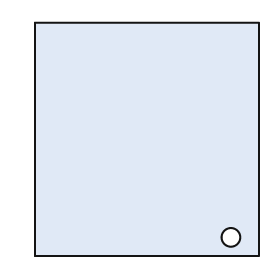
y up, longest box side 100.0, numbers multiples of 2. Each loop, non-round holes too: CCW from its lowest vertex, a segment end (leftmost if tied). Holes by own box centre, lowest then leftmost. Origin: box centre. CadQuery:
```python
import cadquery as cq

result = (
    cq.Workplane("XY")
    .moveTo(-48.0, -50.0)
    .lineTo(48.0, -50.0)
    .lineTo(48.0, 50.0)
    .lineTo(-48.0, 50.0)
    .close()
    .moveTo(36.0, -42.0)
    .circle(4.0)
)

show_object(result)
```